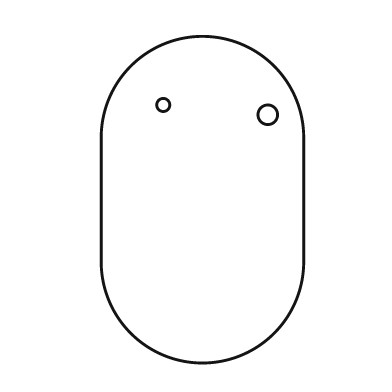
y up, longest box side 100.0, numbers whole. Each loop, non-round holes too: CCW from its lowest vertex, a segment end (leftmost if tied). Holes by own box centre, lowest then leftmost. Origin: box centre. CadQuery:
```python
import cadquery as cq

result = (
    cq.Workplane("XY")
    .moveTo(-31.0, -19.0)
    .threePointArc((0.0, -50.0), (31.0, -19.0))
    .lineTo(31.0, 19.0)
    .threePointArc((0.0, 50.0), (-31.0, 19.0))
    .close()
    .moveTo(20.0, 26.0)
    .circle(3.0)
    .moveTo(-12.0, 29.0)
    .circle(2.0)
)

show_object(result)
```